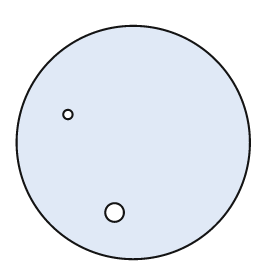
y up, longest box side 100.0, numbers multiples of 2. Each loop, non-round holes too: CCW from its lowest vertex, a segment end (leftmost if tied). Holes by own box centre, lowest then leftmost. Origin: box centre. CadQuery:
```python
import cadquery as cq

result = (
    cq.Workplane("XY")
    .moveTo(0.0, 0.0)
    .circle(50.0)
    .moveTo(-8.0, -30.0)
    .circle(4.0)
    .moveTo(-28.0, 12.0)
    .circle(2.0)
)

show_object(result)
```